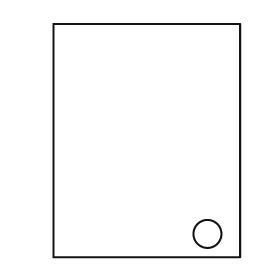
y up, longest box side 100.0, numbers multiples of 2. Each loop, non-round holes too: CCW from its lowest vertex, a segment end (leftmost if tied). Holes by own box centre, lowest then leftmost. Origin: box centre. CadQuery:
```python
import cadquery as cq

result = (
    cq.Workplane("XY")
    .moveTo(-40.0, -50.0)
    .lineTo(40.0, -50.0)
    .lineTo(40.0, 50.0)
    .lineTo(-40.0, 50.0)
    .close()
    .moveTo(26.0, -40.0)
    .circle(6.0)
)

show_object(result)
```